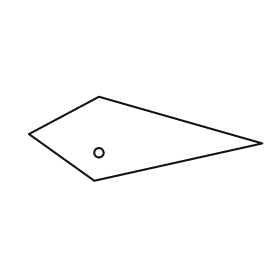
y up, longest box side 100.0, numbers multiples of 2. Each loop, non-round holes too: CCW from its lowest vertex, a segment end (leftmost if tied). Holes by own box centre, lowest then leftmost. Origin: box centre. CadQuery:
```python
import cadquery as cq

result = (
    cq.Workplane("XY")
    .moveTo(-22.0, -18.0)
    .lineTo(50.0, -2.0)
    .lineTo(-20.0, 18.0)
    .lineTo(-50.0, 2.0)
    .close()
    .moveTo(-20.0, -6.0)
    .circle(2.0)
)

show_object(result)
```